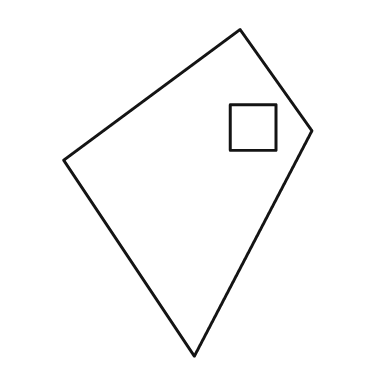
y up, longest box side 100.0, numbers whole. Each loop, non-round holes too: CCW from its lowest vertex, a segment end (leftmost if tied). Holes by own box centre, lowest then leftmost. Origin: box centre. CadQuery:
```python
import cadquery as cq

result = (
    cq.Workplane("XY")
    .moveTo(2.0, -50.0)
    .lineTo(38.0, 19.0)
    .lineTo(16.0, 50.0)
    .lineTo(-38.0, 10.0)
    .close()
    .moveTo(13.0, 13.0)
    .lineTo(27.0, 13.0)
    .lineTo(27.0, 27.0)
    .lineTo(13.0, 27.0)
    .close()
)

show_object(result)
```